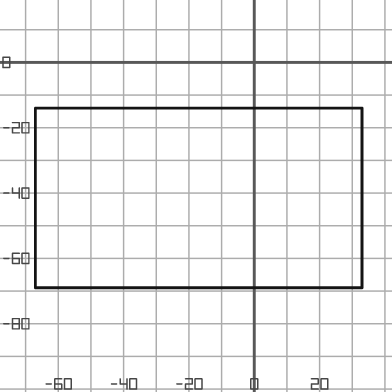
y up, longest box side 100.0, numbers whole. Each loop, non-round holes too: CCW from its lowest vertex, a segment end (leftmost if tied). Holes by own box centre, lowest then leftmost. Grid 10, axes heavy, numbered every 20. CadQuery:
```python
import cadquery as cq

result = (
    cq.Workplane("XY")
    .moveTo(-67.0, -69.0)
    .lineTo(33.0, -69.0)
    .lineTo(33.0, -14.0)
    .lineTo(-67.0, -14.0)
    .close()
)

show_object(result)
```